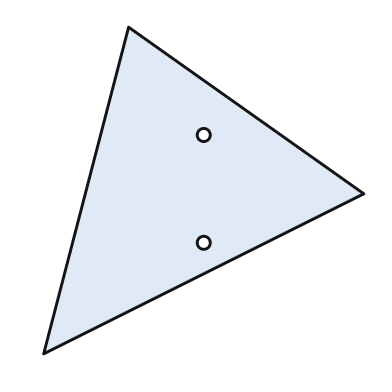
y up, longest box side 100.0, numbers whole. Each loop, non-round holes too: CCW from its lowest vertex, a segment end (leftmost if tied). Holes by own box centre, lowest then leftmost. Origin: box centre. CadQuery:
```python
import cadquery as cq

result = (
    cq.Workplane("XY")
    .moveTo(-49.0, -50.0)
    .lineTo(49.0, -1.0)
    .lineTo(-23.0, 50.0)
    .close()
    .moveTo(0.0, -16.0)
    .circle(2.0)
    .moveTo(0.0, 17.0)
    .circle(2.0)
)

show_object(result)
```